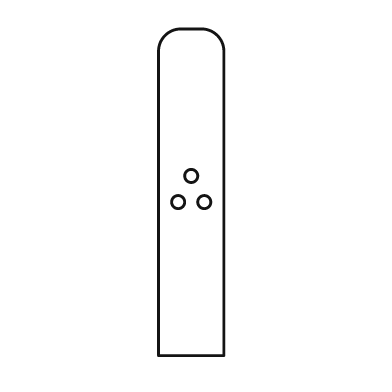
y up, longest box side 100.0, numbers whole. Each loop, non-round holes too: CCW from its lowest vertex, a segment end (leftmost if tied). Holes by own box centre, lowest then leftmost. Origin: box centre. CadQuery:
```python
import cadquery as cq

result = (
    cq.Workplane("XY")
    .moveTo(-10.0, -50.0)
    .lineTo(10.0, -50.0)
    .lineTo(10.0, 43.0)
    .threePointArc((8.0, 48.0), (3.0, 50.0))
    .lineTo(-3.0, 50.0)
    .threePointArc((-8.0, 48.0), (-10.0, 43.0))
    .close()
    .moveTo(-4.0, -3.0)
    .circle(2.0)
    .moveTo(4.0, -3.0)
    .circle(2.0)
    .moveTo(0.0, 5.0)
    .circle(2.0)
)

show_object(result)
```